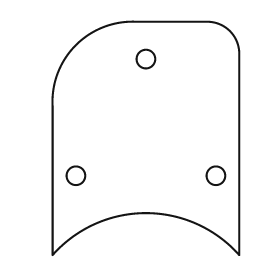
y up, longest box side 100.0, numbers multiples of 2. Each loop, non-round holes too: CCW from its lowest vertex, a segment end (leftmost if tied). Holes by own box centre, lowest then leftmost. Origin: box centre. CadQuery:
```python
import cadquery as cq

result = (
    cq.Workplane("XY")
    .moveTo(-40.0, -50.0)
    .threePointArc((0.0, -32.0), (40.0, -50.0))
    .lineTo(40.0, 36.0)
    .threePointArc((36.0, 46.0), (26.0, 50.0))
    .lineTo(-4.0, 50.0)
    .threePointArc((-30.0, 40.0), (-40.0, 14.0))
    .close()
    .moveTo(-30.0, -16.0)
    .circle(4.0)
    .moveTo(30.0, -16.0)
    .circle(4.0)
    .moveTo(0.0, 34.0)
    .circle(4.0)
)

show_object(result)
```